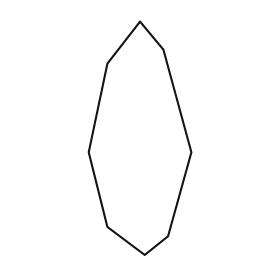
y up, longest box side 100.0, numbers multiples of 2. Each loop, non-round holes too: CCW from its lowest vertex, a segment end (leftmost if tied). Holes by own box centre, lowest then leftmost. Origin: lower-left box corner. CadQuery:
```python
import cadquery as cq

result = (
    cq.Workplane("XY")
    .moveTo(24.0, 0.0)
    .lineTo(34.0, 8.0)
    .lineTo(44.0, 44.0)
    .lineTo(32.0, 88.0)
    .lineTo(22.0, 100.0)
    .lineTo(8.0, 82.0)
    .lineTo(0.0, 44.0)
    .lineTo(8.0, 12.0)
    .close()
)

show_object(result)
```